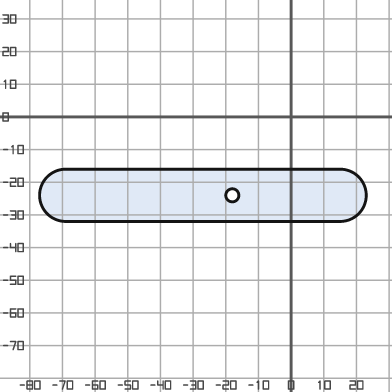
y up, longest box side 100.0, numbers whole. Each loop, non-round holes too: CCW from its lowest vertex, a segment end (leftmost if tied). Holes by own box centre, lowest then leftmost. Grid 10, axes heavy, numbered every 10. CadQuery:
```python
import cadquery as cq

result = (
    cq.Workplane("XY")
    .moveTo(-69.0, -32.0)
    .lineTo(15.0, -32.0)
    .threePointArc((23.0, -24.0), (15.0, -16.0))
    .lineTo(-69.0, -16.0)
    .threePointArc((-77.0, -24.0), (-69.0, -32.0))
    .close()
    .moveTo(-18.0, -24.0)
    .circle(2.0)
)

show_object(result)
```